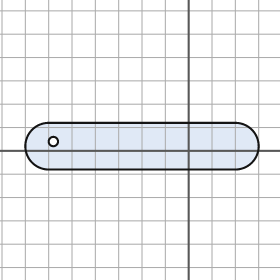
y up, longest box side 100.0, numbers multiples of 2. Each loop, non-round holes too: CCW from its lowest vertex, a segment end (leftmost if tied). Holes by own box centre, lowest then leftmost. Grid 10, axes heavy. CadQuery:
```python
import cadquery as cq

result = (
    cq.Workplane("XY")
    .moveTo(-60.0, -8.0)
    .lineTo(20.0, -8.0)
    .threePointArc((30.0, 2.0), (20.0, 12.0))
    .lineTo(-60.0, 12.0)
    .threePointArc((-70.0, 2.0), (-60.0, -8.0))
    .close()
    .moveTo(-58.0, 4.0)
    .circle(2.0)
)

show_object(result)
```